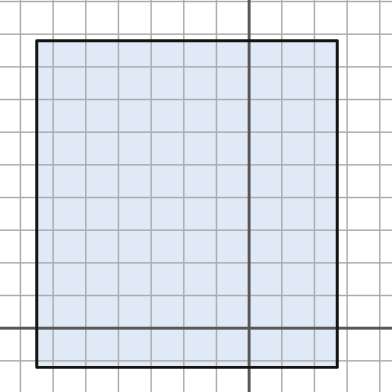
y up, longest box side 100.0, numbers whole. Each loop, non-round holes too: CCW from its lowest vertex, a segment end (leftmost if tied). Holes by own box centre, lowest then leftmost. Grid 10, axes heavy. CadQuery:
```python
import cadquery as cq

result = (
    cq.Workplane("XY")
    .moveTo(-65.0, -12.0)
    .lineTo(27.0, -12.0)
    .lineTo(27.0, 88.0)
    .lineTo(-65.0, 88.0)
    .close()
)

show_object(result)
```